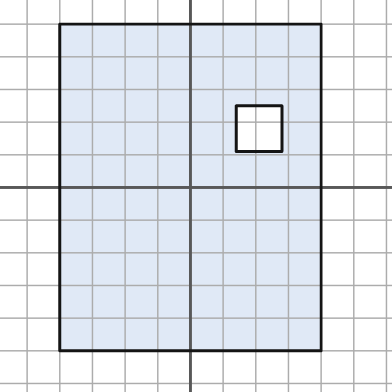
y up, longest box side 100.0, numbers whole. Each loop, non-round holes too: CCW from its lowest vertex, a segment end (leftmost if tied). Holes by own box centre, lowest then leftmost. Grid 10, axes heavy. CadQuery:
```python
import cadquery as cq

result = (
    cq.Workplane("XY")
    .moveTo(-40.0, -50.0)
    .lineTo(40.0, -50.0)
    .lineTo(40.0, 50.0)
    .lineTo(-40.0, 50.0)
    .close()
    .moveTo(14.0, 11.0)
    .lineTo(28.0, 11.0)
    .lineTo(28.0, 25.0)
    .lineTo(14.0, 25.0)
    .close()
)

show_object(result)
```